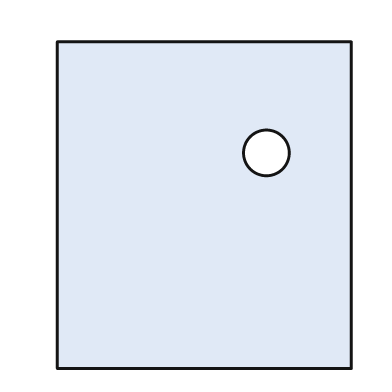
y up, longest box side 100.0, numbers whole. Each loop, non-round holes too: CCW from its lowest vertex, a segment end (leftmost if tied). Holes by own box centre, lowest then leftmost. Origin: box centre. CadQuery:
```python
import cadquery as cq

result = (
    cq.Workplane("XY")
    .moveTo(-45.0, -50.0)
    .lineTo(45.0, -50.0)
    .lineTo(45.0, 50.0)
    .lineTo(-45.0, 50.0)
    .close()
    .moveTo(19.0, 16.0)
    .circle(7.0)
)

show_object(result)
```